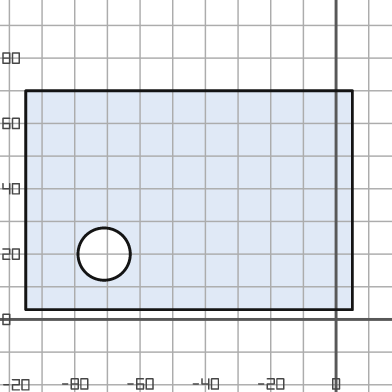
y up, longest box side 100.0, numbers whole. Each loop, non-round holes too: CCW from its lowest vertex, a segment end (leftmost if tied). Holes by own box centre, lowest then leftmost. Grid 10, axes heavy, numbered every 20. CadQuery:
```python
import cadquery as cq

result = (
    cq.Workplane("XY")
    .moveTo(-95.0, 3.0)
    .lineTo(5.0, 3.0)
    .lineTo(5.0, 70.0)
    .lineTo(-95.0, 70.0)
    .close()
    .moveTo(-71.0, 20.0)
    .circle(8.0)
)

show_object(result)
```